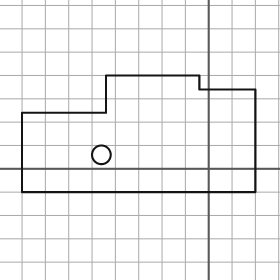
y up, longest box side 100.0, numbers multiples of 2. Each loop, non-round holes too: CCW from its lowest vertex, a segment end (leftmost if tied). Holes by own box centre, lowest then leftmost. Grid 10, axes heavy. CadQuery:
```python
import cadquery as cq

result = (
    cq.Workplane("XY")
    .moveTo(-80.0, -10.0)
    .lineTo(20.0, -10.0)
    .lineTo(20.0, 34.0)
    .lineTo(-4.0, 34.0)
    .lineTo(-4.0, 40.0)
    .lineTo(-44.0, 40.0)
    .lineTo(-44.0, 24.0)
    .lineTo(-80.0, 24.0)
    .close()
    .moveTo(-46.0, 6.0)
    .circle(4.0)
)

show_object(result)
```